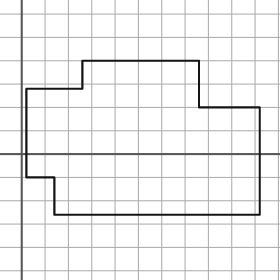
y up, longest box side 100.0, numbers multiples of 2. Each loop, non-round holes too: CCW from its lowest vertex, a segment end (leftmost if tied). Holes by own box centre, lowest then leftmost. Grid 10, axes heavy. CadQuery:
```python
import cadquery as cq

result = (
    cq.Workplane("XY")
    .moveTo(14.0, -26.0)
    .lineTo(102.0, -26.0)
    .lineTo(102.0, 20.0)
    .lineTo(76.0, 20.0)
    .lineTo(76.0, 40.0)
    .lineTo(26.0, 40.0)
    .lineTo(26.0, 28.0)
    .lineTo(2.0, 28.0)
    .lineTo(2.0, -10.0)
    .lineTo(14.0, -10.0)
    .close()
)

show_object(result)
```